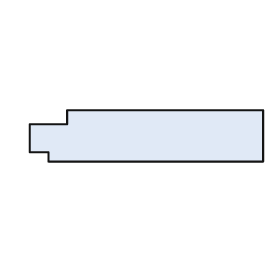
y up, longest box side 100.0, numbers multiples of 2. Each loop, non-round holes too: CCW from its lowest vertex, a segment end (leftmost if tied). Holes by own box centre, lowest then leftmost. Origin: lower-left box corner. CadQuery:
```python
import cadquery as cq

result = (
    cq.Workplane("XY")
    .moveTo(8.0, 0.0)
    .lineTo(100.0, 0.0)
    .lineTo(100.0, 22.0)
    .lineTo(16.0, 22.0)
    .lineTo(16.0, 16.0)
    .lineTo(0.0, 16.0)
    .lineTo(0.0, 4.0)
    .lineTo(8.0, 4.0)
    .close()
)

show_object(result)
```